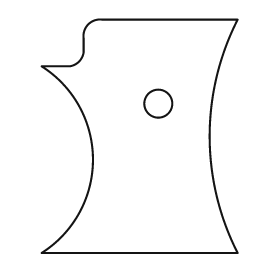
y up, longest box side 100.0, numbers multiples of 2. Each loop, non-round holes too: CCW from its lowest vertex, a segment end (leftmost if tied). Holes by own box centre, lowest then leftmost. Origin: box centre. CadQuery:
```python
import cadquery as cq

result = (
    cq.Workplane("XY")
    .moveTo(-42.0, -50.0)
    .lineTo(42.0, -50.0)
    .threePointArc((30.0, 0.0), (42.0, 50.0))
    .lineTo(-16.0, 50.0)
    .threePointArc((-22.0, 48.0), (-24.0, 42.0))
    .lineTo(-24.0, 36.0)
    .threePointArc((-26.0, 32.0), (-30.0, 30.0))
    .lineTo(-42.0, 30.0)
    .threePointArc((-20.0, -10.0), (-42.0, -50.0))
    .close()
    .moveTo(8.0, 14.0)
    .circle(6.0)
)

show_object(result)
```